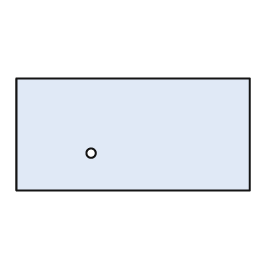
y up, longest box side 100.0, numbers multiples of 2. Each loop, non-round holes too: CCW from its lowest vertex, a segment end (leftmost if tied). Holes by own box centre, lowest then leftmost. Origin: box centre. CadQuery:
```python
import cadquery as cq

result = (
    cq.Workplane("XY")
    .moveTo(-50.0, -24.0)
    .lineTo(50.0, -24.0)
    .lineTo(50.0, 24.0)
    .lineTo(-50.0, 24.0)
    .close()
    .moveTo(-18.0, -8.0)
    .circle(2.0)
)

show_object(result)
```